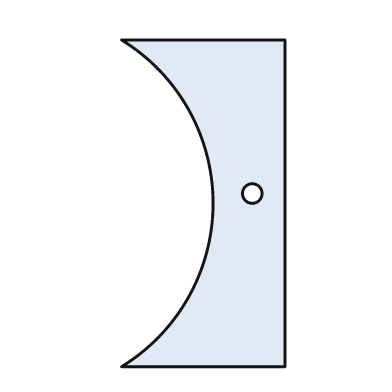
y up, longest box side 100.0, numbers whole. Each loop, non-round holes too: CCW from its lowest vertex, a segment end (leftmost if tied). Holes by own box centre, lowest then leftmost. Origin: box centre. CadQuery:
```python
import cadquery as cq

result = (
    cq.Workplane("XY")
    .moveTo(-25.0, -50.0)
    .lineTo(25.0, -50.0)
    .lineTo(25.0, 50.0)
    .lineTo(-25.0, 50.0)
    .threePointArc((3.0, 0.0), (-25.0, -50.0))
    .close()
    .moveTo(15.0, 3.0)
    .circle(3.0)
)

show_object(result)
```